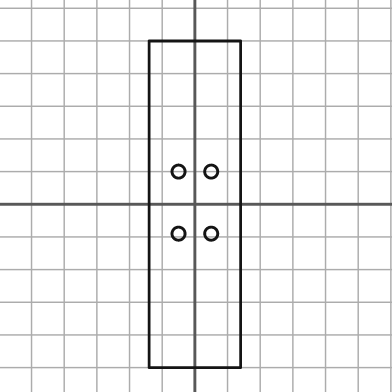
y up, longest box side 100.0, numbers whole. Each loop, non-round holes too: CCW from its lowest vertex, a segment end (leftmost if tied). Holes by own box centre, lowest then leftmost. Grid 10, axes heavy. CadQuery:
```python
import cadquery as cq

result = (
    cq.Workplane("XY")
    .moveTo(-14.0, -50.0)
    .lineTo(14.0, -50.0)
    .lineTo(14.0, 50.0)
    .lineTo(-14.0, 50.0)
    .close()
    .moveTo(-5.0, -9.0)
    .circle(2.0)
    .moveTo(5.0, -9.0)
    .circle(2.0)
    .moveTo(-5.0, 10.0)
    .circle(2.0)
    .moveTo(5.0, 10.0)
    .circle(2.0)
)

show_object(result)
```